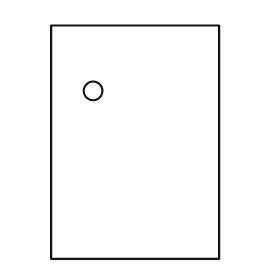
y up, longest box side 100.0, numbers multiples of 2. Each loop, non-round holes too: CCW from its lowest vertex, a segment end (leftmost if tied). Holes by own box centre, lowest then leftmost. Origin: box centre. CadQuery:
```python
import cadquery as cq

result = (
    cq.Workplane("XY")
    .moveTo(-36.0, -50.0)
    .lineTo(36.0, -50.0)
    .lineTo(36.0, 50.0)
    .lineTo(-36.0, 50.0)
    .close()
    .moveTo(-18.0, 22.0)
    .circle(4.0)
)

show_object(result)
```